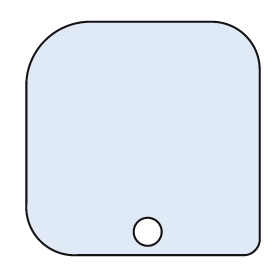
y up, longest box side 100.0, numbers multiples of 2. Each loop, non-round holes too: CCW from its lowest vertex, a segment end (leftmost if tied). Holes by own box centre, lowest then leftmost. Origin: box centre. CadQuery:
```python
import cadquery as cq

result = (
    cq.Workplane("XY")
    .moveTo(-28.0, -50.0)
    .lineTo(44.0, -50.0)
    .threePointArc((48.0, -48.0), (50.0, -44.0))
    .lineTo(50.0, 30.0)
    .threePointArc((44.0, 44.0), (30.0, 50.0))
    .lineTo(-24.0, 50.0)
    .threePointArc((-42.0, 42.0), (-50.0, 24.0))
    .lineTo(-50.0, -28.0)
    .threePointArc((-44.0, -44.0), (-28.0, -50.0))
    .close()
    .moveTo(2.0, -40.0)
    .circle(6.0)
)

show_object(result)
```